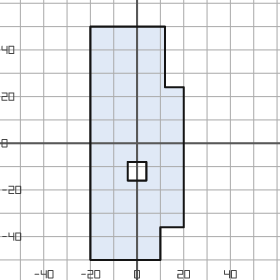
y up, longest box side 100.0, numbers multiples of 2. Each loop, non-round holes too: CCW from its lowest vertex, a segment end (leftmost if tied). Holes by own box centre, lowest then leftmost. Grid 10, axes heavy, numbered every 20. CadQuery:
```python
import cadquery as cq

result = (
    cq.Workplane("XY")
    .moveTo(-20.0, -50.0)
    .lineTo(10.0, -50.0)
    .lineTo(10.0, -36.0)
    .lineTo(20.0, -36.0)
    .lineTo(20.0, 24.0)
    .lineTo(12.0, 24.0)
    .lineTo(12.0, 50.0)
    .lineTo(-20.0, 50.0)
    .close()
    .moveTo(-4.0, -16.0)
    .lineTo(4.0, -16.0)
    .lineTo(4.0, -8.0)
    .lineTo(-4.0, -8.0)
    .close()
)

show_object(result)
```